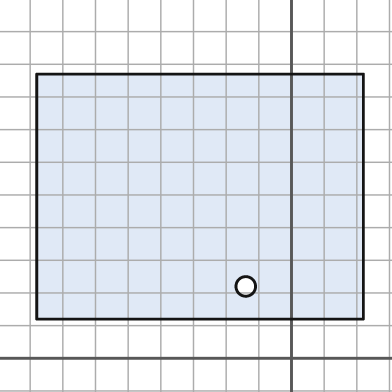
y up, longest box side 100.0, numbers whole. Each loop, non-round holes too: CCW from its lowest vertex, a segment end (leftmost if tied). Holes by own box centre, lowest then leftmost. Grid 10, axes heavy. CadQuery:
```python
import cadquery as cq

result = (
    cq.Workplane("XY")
    .moveTo(-78.0, 12.0)
    .lineTo(22.0, 12.0)
    .lineTo(22.0, 87.0)
    .lineTo(-78.0, 87.0)
    .close()
    .moveTo(-14.0, 22.0)
    .circle(3.0)
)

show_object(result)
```